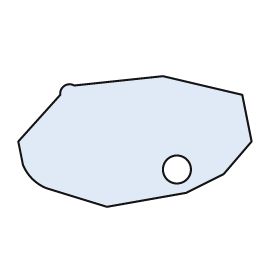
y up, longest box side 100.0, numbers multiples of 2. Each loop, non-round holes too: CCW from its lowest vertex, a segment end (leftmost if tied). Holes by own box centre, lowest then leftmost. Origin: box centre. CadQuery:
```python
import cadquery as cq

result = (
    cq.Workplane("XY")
    .moveTo(-12.0, -28.0)
    .lineTo(22.0, -22.0)
    .lineTo(38.0, -14.0)
    .lineTo(50.0, 0.0)
    .lineTo(46.0, 20.0)
    .lineTo(12.0, 28.0)
    .lineTo(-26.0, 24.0)
    .threePointArc((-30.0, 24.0), (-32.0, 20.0))
    .lineTo(-50.0, 0.0)
    .lineTo(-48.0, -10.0)
    .threePointArc((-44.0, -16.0), (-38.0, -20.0))
    .close()
    .moveTo(18.0, -12.0)
    .circle(6.0)
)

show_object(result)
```